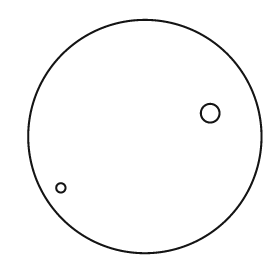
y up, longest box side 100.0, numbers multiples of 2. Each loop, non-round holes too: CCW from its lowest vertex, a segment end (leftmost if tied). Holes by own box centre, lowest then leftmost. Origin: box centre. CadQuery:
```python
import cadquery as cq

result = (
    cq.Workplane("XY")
    .moveTo(0.0, 0.0)
    .circle(50.0)
    .moveTo(-36.0, -22.0)
    .circle(2.0)
    .moveTo(28.0, 10.0)
    .circle(4.0)
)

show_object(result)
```